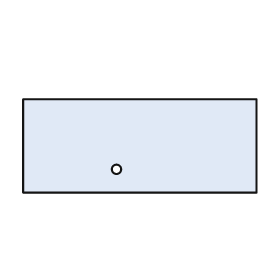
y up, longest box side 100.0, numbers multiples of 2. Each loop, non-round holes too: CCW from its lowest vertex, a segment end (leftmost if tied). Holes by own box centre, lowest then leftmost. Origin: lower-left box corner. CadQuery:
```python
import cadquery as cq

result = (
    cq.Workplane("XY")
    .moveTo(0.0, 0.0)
    .lineTo(100.0, 0.0)
    .lineTo(100.0, 40.0)
    .lineTo(0.0, 40.0)
    .close()
    .moveTo(40.0, 10.0)
    .circle(2.0)
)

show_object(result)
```